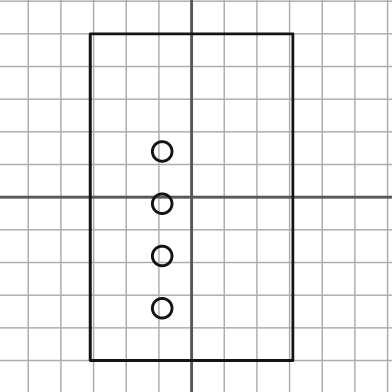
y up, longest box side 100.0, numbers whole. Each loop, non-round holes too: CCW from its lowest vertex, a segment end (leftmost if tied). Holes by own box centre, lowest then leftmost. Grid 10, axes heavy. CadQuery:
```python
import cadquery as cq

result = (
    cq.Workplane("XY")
    .moveTo(-31.0, -50.0)
    .lineTo(31.0, -50.0)
    .lineTo(31.0, 50.0)
    .lineTo(-31.0, 50.0)
    .close()
    .moveTo(-9.0, -34.0)
    .circle(3.0)
    .moveTo(-9.0, -18.0)
    .circle(3.0)
    .moveTo(-9.0, -2.0)
    .circle(3.0)
    .moveTo(-9.0, 14.0)
    .circle(3.0)
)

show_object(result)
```